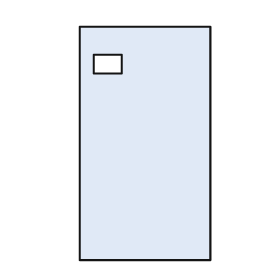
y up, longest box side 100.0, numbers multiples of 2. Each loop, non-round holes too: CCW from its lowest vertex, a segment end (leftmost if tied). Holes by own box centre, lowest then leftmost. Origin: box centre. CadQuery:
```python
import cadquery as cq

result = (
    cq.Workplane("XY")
    .moveTo(-28.0, -50.0)
    .lineTo(28.0, -50.0)
    .lineTo(28.0, 50.0)
    .lineTo(-28.0, 50.0)
    .close()
    .moveTo(-22.0, 30.0)
    .lineTo(-10.0, 30.0)
    .lineTo(-10.0, 38.0)
    .lineTo(-22.0, 38.0)
    .close()
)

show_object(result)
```